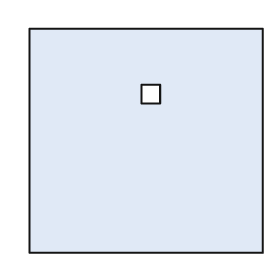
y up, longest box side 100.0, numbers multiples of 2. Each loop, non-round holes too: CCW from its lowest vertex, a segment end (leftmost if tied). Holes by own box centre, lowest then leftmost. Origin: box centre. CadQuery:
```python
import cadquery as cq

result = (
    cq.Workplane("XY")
    .moveTo(-50.0, -48.0)
    .lineTo(50.0, -48.0)
    .lineTo(50.0, 48.0)
    .lineTo(-50.0, 48.0)
    .close()
    .moveTo(-2.0, 16.0)
    .lineTo(6.0, 16.0)
    .lineTo(6.0, 24.0)
    .lineTo(-2.0, 24.0)
    .close()
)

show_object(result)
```